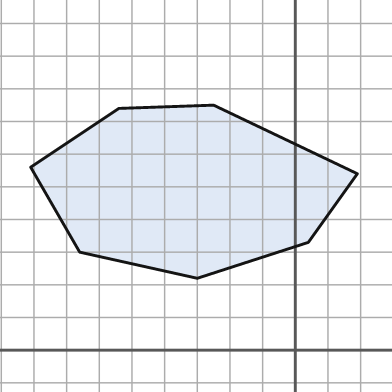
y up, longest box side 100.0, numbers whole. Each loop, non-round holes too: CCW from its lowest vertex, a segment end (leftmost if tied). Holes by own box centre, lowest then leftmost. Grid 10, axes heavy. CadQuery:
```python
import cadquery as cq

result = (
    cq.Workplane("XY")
    .moveTo(-30.0, 22.0)
    .lineTo(4.0, 33.0)
    .lineTo(19.0, 54.0)
    .lineTo(-25.0, 75.0)
    .lineTo(-54.0, 74.0)
    .lineTo(-81.0, 56.0)
    .lineTo(-66.0, 30.0)
    .close()
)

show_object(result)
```